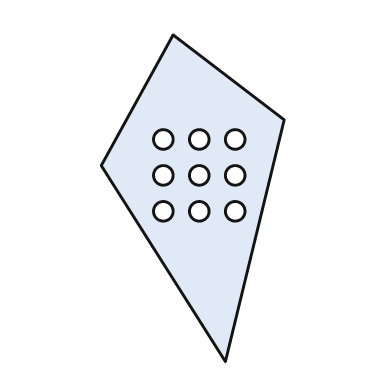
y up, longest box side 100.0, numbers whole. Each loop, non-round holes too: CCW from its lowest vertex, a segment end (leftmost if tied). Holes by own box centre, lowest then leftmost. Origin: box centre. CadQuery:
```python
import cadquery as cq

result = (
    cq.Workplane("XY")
    .moveTo(10.0, -50.0)
    .lineTo(28.0, 24.0)
    .lineTo(-6.0, 50.0)
    .lineTo(-28.0, 10.0)
    .close()
    .moveTo(-9.0, -4.0)
    .circle(3.0)
    .moveTo(2.0, -4.0)
    .circle(3.0)
    .moveTo(13.0, -4.0)
    .circle(3.0)
    .moveTo(-9.0, 7.0)
    .circle(3.0)
    .moveTo(2.0, 7.0)
    .circle(3.0)
    .moveTo(13.0, 7.0)
    .circle(3.0)
    .moveTo(-9.0, 18.0)
    .circle(3.0)
    .moveTo(2.0, 18.0)
    .circle(3.0)
    .moveTo(13.0, 18.0)
    .circle(3.0)
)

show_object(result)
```